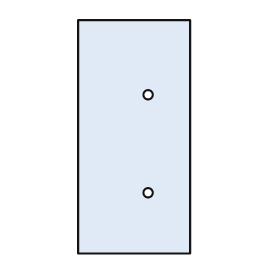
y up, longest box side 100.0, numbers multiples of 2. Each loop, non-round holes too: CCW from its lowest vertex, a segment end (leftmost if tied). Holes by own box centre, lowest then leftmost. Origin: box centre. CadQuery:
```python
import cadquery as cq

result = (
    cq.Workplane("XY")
    .moveTo(-24.0, -50.0)
    .lineTo(24.0, -50.0)
    .lineTo(24.0, 50.0)
    .lineTo(-24.0, 50.0)
    .close()
    .moveTo(6.0, -24.0)
    .circle(2.0)
    .moveTo(6.0, 18.0)
    .circle(2.0)
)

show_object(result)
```